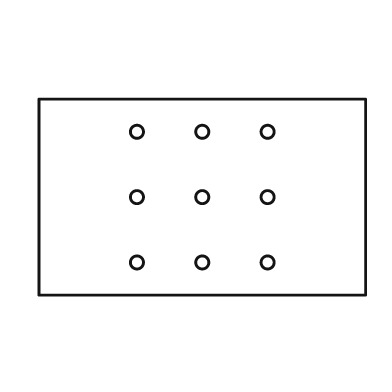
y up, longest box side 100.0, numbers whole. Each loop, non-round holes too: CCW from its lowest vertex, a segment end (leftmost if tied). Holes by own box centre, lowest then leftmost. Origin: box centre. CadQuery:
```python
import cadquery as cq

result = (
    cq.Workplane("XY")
    .moveTo(-50.0, -30.0)
    .lineTo(50.0, -30.0)
    .lineTo(50.0, 30.0)
    .lineTo(-50.0, 30.0)
    .close()
    .moveTo(-20.0, -20.0)
    .circle(2.0)
    .moveTo(0.0, -20.0)
    .circle(2.0)
    .moveTo(20.0, -20.0)
    .circle(2.0)
    .moveTo(-20.0, 0.0)
    .circle(2.0)
    .moveTo(0.0, 0.0)
    .circle(2.0)
    .moveTo(20.0, 0.0)
    .circle(2.0)
    .moveTo(-20.0, 20.0)
    .circle(2.0)
    .moveTo(0.0, 20.0)
    .circle(2.0)
    .moveTo(20.0, 20.0)
    .circle(2.0)
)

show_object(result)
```